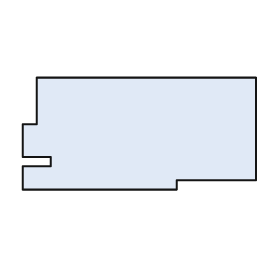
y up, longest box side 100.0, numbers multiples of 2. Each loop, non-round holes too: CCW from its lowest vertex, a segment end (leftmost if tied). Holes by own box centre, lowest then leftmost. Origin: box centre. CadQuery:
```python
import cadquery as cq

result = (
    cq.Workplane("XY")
    .moveTo(-50.0, -24.0)
    .lineTo(16.0, -24.0)
    .lineTo(16.0, -20.0)
    .lineTo(50.0, -20.0)
    .lineTo(50.0, 24.0)
    .lineTo(-44.0, 24.0)
    .lineTo(-44.0, 4.0)
    .lineTo(-50.0, 4.0)
    .lineTo(-50.0, -10.0)
    .lineTo(-38.0, -10.0)
    .lineTo(-38.0, -14.0)
    .lineTo(-50.0, -14.0)
    .close()
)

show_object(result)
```